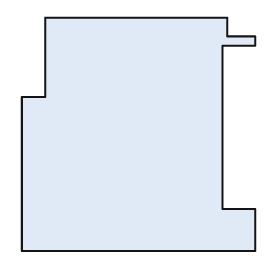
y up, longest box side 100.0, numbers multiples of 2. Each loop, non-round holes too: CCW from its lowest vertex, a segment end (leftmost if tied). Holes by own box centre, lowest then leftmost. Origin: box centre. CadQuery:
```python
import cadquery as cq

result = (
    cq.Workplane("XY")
    .moveTo(-50.0, -50.0)
    .lineTo(50.0, -50.0)
    .lineTo(50.0, -32.0)
    .lineTo(36.0, -32.0)
    .lineTo(36.0, 38.0)
    .lineTo(50.0, 38.0)
    .lineTo(50.0, 42.0)
    .lineTo(38.0, 42.0)
    .lineTo(38.0, 50.0)
    .lineTo(-40.0, 50.0)
    .lineTo(-40.0, 16.0)
    .lineTo(-50.0, 16.0)
    .close()
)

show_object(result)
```